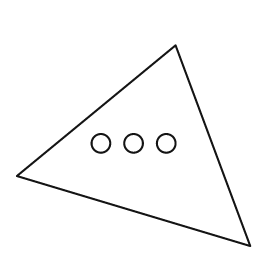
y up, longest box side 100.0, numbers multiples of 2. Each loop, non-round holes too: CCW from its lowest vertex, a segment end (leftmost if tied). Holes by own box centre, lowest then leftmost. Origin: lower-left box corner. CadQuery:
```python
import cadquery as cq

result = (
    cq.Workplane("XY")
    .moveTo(100.0, 0.0)
    .lineTo(68.0, 86.0)
    .lineTo(0.0, 30.0)
    .close()
    .moveTo(36.0, 44.0)
    .circle(4.0)
    .moveTo(50.0, 44.0)
    .circle(4.0)
    .moveTo(64.0, 44.0)
    .circle(4.0)
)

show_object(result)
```